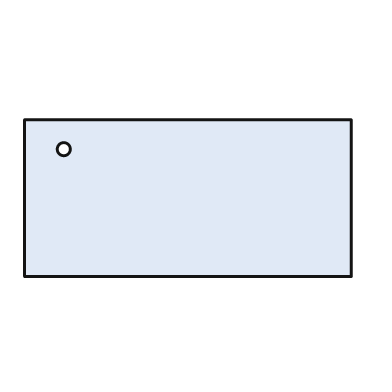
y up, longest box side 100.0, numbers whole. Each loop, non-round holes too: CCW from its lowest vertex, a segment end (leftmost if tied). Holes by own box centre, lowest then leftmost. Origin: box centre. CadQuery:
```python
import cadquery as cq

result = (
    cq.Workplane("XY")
    .moveTo(-50.0, -24.0)
    .lineTo(50.0, -24.0)
    .lineTo(50.0, 24.0)
    .lineTo(-50.0, 24.0)
    .close()
    .moveTo(-38.0, 15.0)
    .circle(2.0)
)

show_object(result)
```